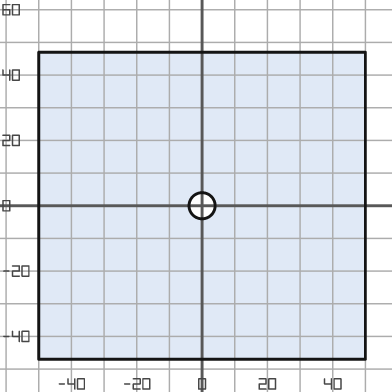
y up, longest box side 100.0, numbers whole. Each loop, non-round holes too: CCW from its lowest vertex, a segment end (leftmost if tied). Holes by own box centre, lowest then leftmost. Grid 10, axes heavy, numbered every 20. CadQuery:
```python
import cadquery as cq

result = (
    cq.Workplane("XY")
    .moveTo(-50.0, -47.0)
    .lineTo(50.0, -47.0)
    .lineTo(50.0, 47.0)
    .lineTo(-50.0, 47.0)
    .close()
    .moveTo(0.0, 0.0)
    .circle(4.0)
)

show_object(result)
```